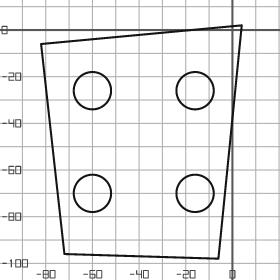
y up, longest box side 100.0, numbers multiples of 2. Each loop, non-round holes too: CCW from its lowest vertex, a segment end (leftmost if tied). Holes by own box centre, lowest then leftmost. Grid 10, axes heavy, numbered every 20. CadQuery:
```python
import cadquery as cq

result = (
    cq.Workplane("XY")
    .moveTo(-6.0, -98.0)
    .lineTo(4.0, 2.0)
    .lineTo(-82.0, -6.0)
    .lineTo(-72.0, -96.0)
    .close()
    .moveTo(-60.0, -70.0)
    .circle(8.0)
    .moveTo(-16.0, -70.0)
    .circle(8.0)
    .moveTo(-60.0, -26.0)
    .circle(8.0)
    .moveTo(-16.0, -26.0)
    .circle(8.0)
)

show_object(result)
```